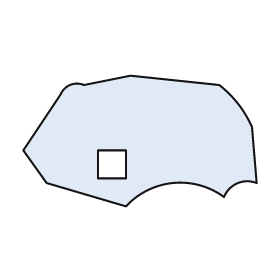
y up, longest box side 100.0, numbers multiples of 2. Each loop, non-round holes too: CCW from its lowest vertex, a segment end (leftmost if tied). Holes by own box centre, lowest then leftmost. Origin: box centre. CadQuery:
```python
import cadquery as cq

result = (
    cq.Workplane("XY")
    .moveTo(-6.0, -28.0)
    .threePointArc((14.0, -18.0), (36.0, -24.0))
    .threePointArc((42.0, -18.0), (50.0, -18.0))
    .lineTo(48.0, 6.0)
    .threePointArc((42.0, 16.0), (34.0, 24.0))
    .lineTo(-4.0, 28.0)
    .lineTo(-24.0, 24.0)
    .threePointArc((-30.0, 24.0), (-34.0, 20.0))
    .lineTo(-50.0, -4.0)
    .lineTo(-40.0, -18.0)
    .close()
    .moveTo(-18.0, -16.0)
    .lineTo(-6.0, -16.0)
    .lineTo(-6.0, -4.0)
    .lineTo(-18.0, -4.0)
    .close()
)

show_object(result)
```